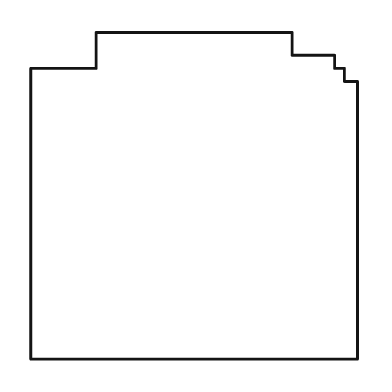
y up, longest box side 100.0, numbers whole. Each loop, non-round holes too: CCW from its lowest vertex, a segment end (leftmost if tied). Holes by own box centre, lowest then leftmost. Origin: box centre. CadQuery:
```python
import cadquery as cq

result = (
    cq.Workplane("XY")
    .moveTo(-50.0, -50.0)
    .lineTo(50.0, -50.0)
    .lineTo(50.0, 35.0)
    .lineTo(46.0, 35.0)
    .lineTo(46.0, 39.0)
    .lineTo(43.0, 39.0)
    .lineTo(43.0, 43.0)
    .lineTo(30.0, 43.0)
    .lineTo(30.0, 50.0)
    .lineTo(-30.0, 50.0)
    .lineTo(-30.0, 39.0)
    .lineTo(-50.0, 39.0)
    .close()
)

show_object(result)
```